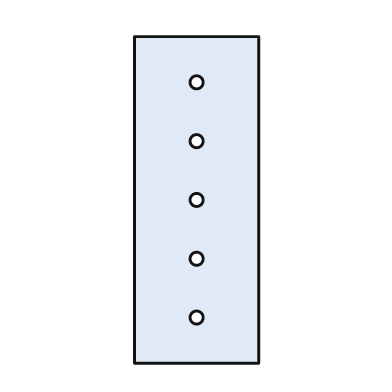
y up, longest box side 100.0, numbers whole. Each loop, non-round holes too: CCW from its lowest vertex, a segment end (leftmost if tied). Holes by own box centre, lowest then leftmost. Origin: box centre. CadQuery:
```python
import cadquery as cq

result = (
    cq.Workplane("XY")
    .moveTo(-19.0, -50.0)
    .lineTo(19.0, -50.0)
    .lineTo(19.0, 50.0)
    .lineTo(-19.0, 50.0)
    .close()
    .moveTo(0.0, -36.0)
    .circle(2.0)
    .moveTo(0.0, -18.0)
    .circle(2.0)
    .moveTo(0.0, 0.0)
    .circle(2.0)
    .moveTo(0.0, 18.0)
    .circle(2.0)
    .moveTo(0.0, 36.0)
    .circle(2.0)
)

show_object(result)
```